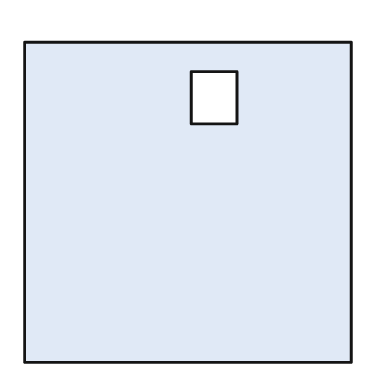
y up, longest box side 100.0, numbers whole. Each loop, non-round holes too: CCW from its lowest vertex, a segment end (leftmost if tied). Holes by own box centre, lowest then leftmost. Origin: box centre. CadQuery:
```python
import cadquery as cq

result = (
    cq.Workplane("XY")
    .moveTo(-50.0, -49.0)
    .lineTo(50.0, -49.0)
    .lineTo(50.0, 49.0)
    .lineTo(-50.0, 49.0)
    .close()
    .moveTo(1.0, 24.0)
    .lineTo(15.0, 24.0)
    .lineTo(15.0, 40.0)
    .lineTo(1.0, 40.0)
    .close()
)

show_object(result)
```